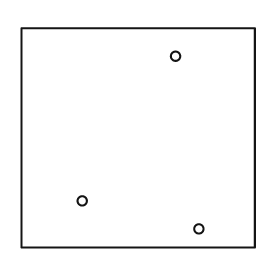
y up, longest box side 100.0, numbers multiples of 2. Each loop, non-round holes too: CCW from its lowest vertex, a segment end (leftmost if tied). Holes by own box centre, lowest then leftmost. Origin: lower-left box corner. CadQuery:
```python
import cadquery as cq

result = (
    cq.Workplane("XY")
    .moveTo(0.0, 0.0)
    .lineTo(100.0, 0.0)
    .lineTo(100.0, 94.0)
    .lineTo(0.0, 94.0)
    .close()
    .moveTo(76.0, 8.0)
    .circle(2.0)
    .moveTo(26.0, 20.0)
    .circle(2.0)
    .moveTo(66.0, 82.0)
    .circle(2.0)
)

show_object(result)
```